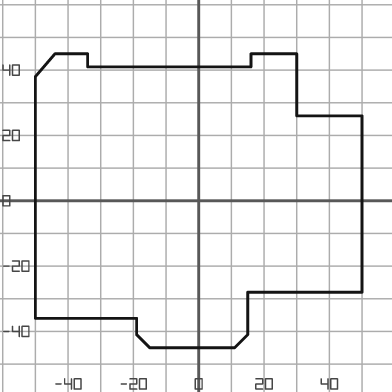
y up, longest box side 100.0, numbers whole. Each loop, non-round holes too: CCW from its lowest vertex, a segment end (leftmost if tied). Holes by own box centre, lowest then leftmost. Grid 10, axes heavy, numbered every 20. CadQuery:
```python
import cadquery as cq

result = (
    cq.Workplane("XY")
    .moveTo(-15.0, -45.0)
    .lineTo(11.0, -45.0)
    .lineTo(15.0, -41.0)
    .lineTo(15.0, -28.0)
    .lineTo(50.0, -28.0)
    .lineTo(50.0, 26.0)
    .lineTo(30.0, 26.0)
    .lineTo(30.0, 45.0)
    .lineTo(16.0, 45.0)
    .lineTo(16.0, 41.0)
    .lineTo(-34.0, 41.0)
    .lineTo(-34.0, 45.0)
    .lineTo(-44.0, 45.0)
    .lineTo(-50.0, 38.0)
    .lineTo(-50.0, -36.0)
    .lineTo(-19.0, -36.0)
    .lineTo(-19.0, -41.0)
    .close()
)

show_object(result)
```